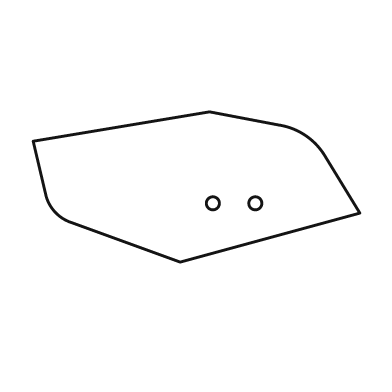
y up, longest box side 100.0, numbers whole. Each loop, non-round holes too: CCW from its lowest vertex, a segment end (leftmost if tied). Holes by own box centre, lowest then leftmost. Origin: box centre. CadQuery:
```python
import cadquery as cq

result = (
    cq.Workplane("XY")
    .moveTo(-5.0, -23.0)
    .lineTo(50.0, -8.0)
    .lineTo(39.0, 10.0)
    .threePointArc((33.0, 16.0), (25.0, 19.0))
    .lineTo(4.0, 23.0)
    .lineTo(-50.0, 14.0)
    .lineTo(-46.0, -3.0)
    .threePointArc((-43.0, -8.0), (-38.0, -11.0))
    .close()
    .moveTo(5.0, -5.0)
    .circle(2.0)
    .moveTo(18.0, -5.0)
    .circle(2.0)
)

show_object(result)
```